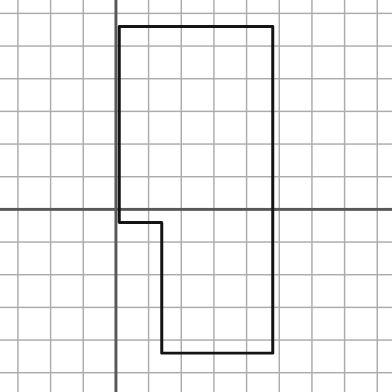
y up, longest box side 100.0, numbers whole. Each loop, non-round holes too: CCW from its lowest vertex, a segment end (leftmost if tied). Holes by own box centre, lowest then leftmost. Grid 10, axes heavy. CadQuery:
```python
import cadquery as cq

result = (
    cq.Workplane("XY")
    .moveTo(14.0, -44.0)
    .lineTo(48.0, -44.0)
    .lineTo(48.0, 56.0)
    .lineTo(1.0, 56.0)
    .lineTo(1.0, -4.0)
    .lineTo(14.0, -4.0)
    .close()
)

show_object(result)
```